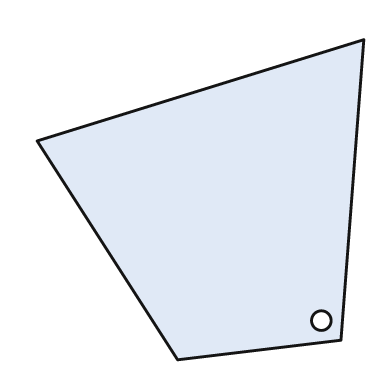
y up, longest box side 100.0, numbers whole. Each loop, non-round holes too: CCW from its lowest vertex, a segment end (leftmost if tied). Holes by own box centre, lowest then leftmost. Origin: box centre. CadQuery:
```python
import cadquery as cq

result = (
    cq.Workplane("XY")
    .moveTo(-7.0, -49.0)
    .lineTo(43.0, -43.0)
    .lineTo(50.0, 49.0)
    .lineTo(-50.0, 18.0)
    .close()
    .moveTo(37.0, -37.0)
    .circle(3.0)
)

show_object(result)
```